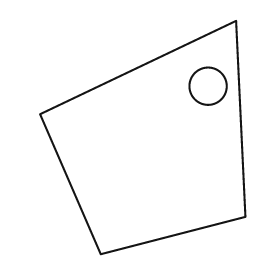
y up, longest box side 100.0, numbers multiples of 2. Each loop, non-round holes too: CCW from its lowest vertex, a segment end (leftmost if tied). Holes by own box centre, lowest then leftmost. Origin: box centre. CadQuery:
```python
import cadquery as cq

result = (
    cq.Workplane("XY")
    .moveTo(-18.0, -50.0)
    .lineTo(44.0, -34.0)
    .lineTo(40.0, 50.0)
    .lineTo(-44.0, 10.0)
    .close()
    .moveTo(28.0, 22.0)
    .circle(8.0)
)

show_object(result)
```